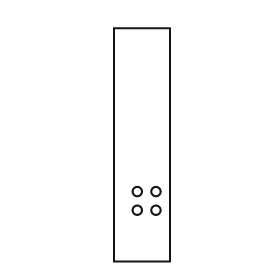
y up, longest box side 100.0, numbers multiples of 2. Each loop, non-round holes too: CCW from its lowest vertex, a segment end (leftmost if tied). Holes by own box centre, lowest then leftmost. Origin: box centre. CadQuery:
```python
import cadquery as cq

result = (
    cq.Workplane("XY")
    .moveTo(-12.0, -50.0)
    .lineTo(12.0, -50.0)
    .lineTo(12.0, 50.0)
    .lineTo(-12.0, 50.0)
    .close()
    .moveTo(-2.0, -28.0)
    .circle(2.0)
    .moveTo(6.0, -28.0)
    .circle(2.0)
    .moveTo(-2.0, -20.0)
    .circle(2.0)
    .moveTo(6.0, -20.0)
    .circle(2.0)
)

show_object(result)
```